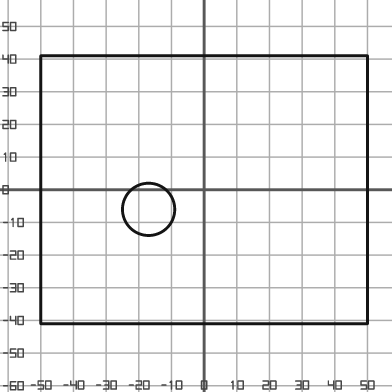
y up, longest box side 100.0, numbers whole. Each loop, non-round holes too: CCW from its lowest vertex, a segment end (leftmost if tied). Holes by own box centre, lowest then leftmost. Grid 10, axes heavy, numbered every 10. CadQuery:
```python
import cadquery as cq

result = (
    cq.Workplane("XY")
    .moveTo(-50.0, -41.0)
    .lineTo(50.0, -41.0)
    .lineTo(50.0, 41.0)
    .lineTo(-50.0, 41.0)
    .close()
    .moveTo(-17.0, -6.0)
    .circle(8.0)
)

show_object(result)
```